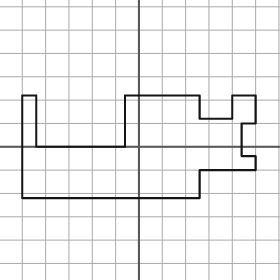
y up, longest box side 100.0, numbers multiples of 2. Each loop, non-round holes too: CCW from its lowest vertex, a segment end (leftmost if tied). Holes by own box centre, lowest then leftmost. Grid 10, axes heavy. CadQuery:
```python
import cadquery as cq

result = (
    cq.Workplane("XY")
    .moveTo(-50.0, -22.0)
    .lineTo(26.0, -22.0)
    .lineTo(26.0, -10.0)
    .lineTo(50.0, -10.0)
    .lineTo(50.0, -4.0)
    .lineTo(44.0, -4.0)
    .lineTo(44.0, 10.0)
    .lineTo(50.0, 10.0)
    .lineTo(50.0, 22.0)
    .lineTo(40.0, 22.0)
    .lineTo(40.0, 12.0)
    .lineTo(26.0, 12.0)
    .lineTo(26.0, 22.0)
    .lineTo(-6.0, 22.0)
    .lineTo(-6.0, 0.0)
    .lineTo(-44.0, 0.0)
    .lineTo(-44.0, 22.0)
    .lineTo(-50.0, 22.0)
    .close()
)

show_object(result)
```